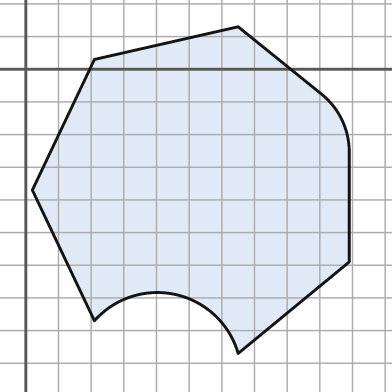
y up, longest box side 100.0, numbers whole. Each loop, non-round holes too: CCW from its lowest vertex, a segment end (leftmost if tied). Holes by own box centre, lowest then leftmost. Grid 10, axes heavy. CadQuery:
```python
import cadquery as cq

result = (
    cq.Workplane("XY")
    .moveTo(65.0, -87.0)
    .lineTo(99.0, -59.0)
    .lineTo(99.0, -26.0)
    .threePointArc((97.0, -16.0), (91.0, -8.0))
    .lineTo(65.0, 13.0)
    .lineTo(21.0, 3.0)
    .lineTo(2.0, -37.0)
    .lineTo(21.0, -77.0)
    .threePointArc((46.0, -69.0), (65.0, -87.0))
    .close()
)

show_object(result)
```